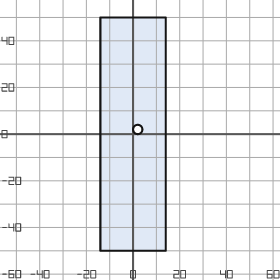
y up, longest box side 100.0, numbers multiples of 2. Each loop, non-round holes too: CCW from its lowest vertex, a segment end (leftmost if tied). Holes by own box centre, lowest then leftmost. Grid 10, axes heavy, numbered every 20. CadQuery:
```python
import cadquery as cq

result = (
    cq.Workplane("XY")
    .moveTo(-14.0, -50.0)
    .lineTo(14.0, -50.0)
    .lineTo(14.0, 50.0)
    .lineTo(-14.0, 50.0)
    .close()
    .moveTo(2.0, 2.0)
    .circle(2.0)
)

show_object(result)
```